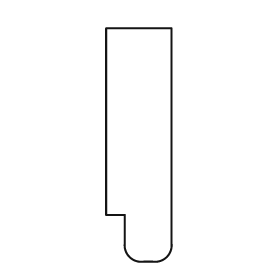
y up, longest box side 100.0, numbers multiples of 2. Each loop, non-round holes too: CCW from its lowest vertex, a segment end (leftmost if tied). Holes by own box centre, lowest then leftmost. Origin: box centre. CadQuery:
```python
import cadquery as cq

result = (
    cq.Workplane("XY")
    .moveTo(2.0, -50.0)
    .lineTo(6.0, -50.0)
    .threePointArc((12.0, -48.0), (14.0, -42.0))
    .lineTo(14.0, 50.0)
    .lineTo(-14.0, 50.0)
    .lineTo(-14.0, -30.0)
    .lineTo(-6.0, -30.0)
    .lineTo(-6.0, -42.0)
    .threePointArc((-4.0, -48.0), (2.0, -50.0))
    .close()
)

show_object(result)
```